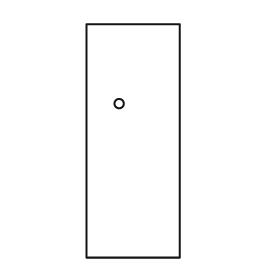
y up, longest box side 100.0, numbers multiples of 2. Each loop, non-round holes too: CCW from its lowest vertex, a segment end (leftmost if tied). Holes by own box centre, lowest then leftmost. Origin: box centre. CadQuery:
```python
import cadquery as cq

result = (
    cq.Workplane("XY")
    .moveTo(-20.0, -50.0)
    .lineTo(20.0, -50.0)
    .lineTo(20.0, 50.0)
    .lineTo(-20.0, 50.0)
    .close()
    .moveTo(-6.0, 16.0)
    .circle(2.0)
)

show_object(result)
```